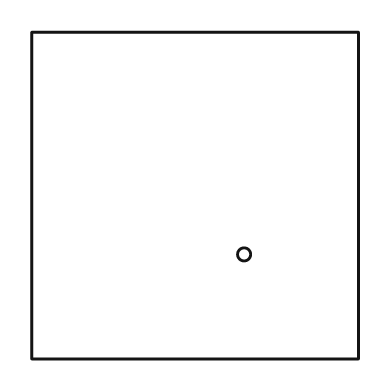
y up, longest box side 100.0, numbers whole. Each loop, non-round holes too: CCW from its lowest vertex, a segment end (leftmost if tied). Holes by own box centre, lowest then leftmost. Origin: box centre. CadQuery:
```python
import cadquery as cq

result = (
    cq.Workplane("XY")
    .moveTo(-50.0, -50.0)
    .lineTo(50.0, -50.0)
    .lineTo(50.0, 50.0)
    .lineTo(-50.0, 50.0)
    .close()
    .moveTo(15.0, -18.0)
    .circle(2.0)
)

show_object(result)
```